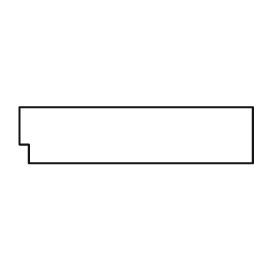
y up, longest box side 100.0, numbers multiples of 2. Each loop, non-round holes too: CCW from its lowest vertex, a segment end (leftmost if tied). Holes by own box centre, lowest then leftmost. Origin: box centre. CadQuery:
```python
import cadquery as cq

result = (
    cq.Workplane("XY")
    .moveTo(-46.0, -12.0)
    .lineTo(50.0, -12.0)
    .lineTo(50.0, 12.0)
    .lineTo(-50.0, 12.0)
    .lineTo(-50.0, -4.0)
    .lineTo(-46.0, -4.0)
    .close()
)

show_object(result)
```